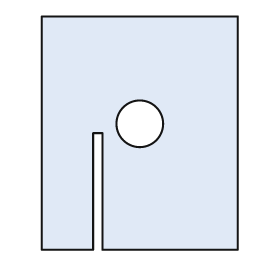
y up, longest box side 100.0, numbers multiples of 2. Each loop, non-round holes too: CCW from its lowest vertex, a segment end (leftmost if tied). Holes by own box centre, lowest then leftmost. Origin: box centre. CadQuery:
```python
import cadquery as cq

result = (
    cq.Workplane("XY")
    .moveTo(-42.0, -50.0)
    .lineTo(-20.0, -50.0)
    .lineTo(-20.0, 0.0)
    .lineTo(-16.0, 0.0)
    .lineTo(-16.0, -50.0)
    .lineTo(42.0, -50.0)
    .lineTo(42.0, 50.0)
    .lineTo(-42.0, 50.0)
    .close()
    .moveTo(0.0, 4.0)
    .circle(10.0)
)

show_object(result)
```